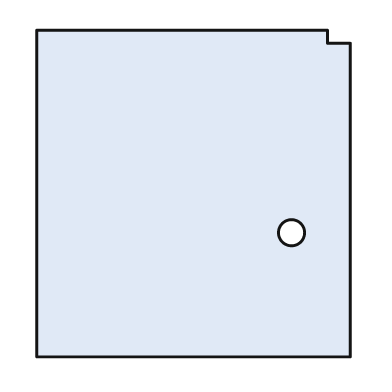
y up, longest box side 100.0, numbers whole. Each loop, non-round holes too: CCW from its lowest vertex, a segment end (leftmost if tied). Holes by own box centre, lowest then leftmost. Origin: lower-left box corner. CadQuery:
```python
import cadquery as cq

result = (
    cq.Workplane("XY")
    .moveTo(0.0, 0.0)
    .lineTo(96.0, 0.0)
    .lineTo(96.0, 96.0)
    .lineTo(89.0, 96.0)
    .lineTo(89.0, 100.0)
    .lineTo(0.0, 100.0)
    .close()
    .moveTo(78.0, 38.0)
    .circle(4.0)
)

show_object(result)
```